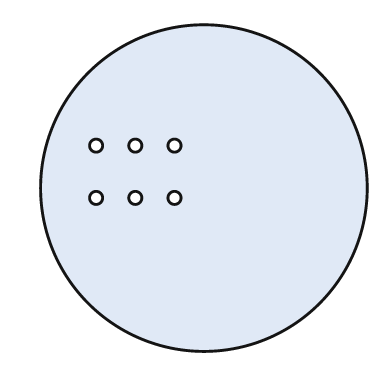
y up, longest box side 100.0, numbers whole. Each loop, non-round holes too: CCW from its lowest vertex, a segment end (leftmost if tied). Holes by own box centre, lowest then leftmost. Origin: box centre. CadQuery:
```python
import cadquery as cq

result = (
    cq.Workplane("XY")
    .moveTo(0.0, 0.0)
    .circle(50.0)
    .moveTo(-33.0, -3.0)
    .circle(2.0)
    .moveTo(-21.0, -3.0)
    .circle(2.0)
    .moveTo(-9.0, -3.0)
    .circle(2.0)
    .moveTo(-33.0, 13.0)
    .circle(2.0)
    .moveTo(-21.0, 13.0)
    .circle(2.0)
    .moveTo(-9.0, 13.0)
    .circle(2.0)
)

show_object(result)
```